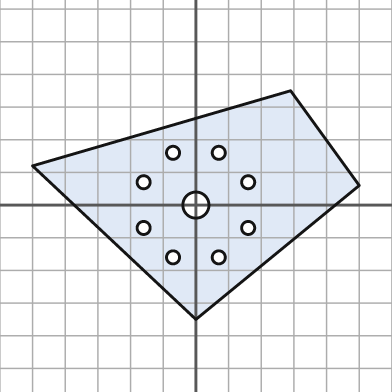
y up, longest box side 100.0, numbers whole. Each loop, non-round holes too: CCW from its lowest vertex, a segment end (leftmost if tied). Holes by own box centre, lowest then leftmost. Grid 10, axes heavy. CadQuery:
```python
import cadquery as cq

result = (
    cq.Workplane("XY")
    .moveTo(0.0, -35.0)
    .lineTo(50.0, 6.0)
    .lineTo(29.0, 35.0)
    .lineTo(-50.0, 12.0)
    .close()
    .moveTo(-7.0, -16.0)
    .circle(2.0)
    .moveTo(7.0, -16.0)
    .circle(2.0)
    .moveTo(-16.0, -7.0)
    .circle(2.0)
    .moveTo(16.0, -7.0)
    .circle(2.0)
    .moveTo(0.0, 0.0)
    .circle(4.0)
    .moveTo(-16.0, 7.0)
    .circle(2.0)
    .moveTo(16.0, 7.0)
    .circle(2.0)
    .moveTo(-7.0, 16.0)
    .circle(2.0)
    .moveTo(7.0, 16.0)
    .circle(2.0)
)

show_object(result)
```